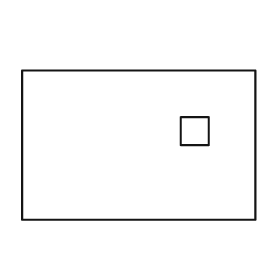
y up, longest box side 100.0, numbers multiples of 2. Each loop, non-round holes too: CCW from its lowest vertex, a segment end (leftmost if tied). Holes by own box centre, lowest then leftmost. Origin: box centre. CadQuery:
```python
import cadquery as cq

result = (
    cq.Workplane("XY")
    .moveTo(-50.0, -32.0)
    .lineTo(50.0, -32.0)
    .lineTo(50.0, 32.0)
    .lineTo(-50.0, 32.0)
    .close()
    .moveTo(18.0, 0.0)
    .lineTo(30.0, 0.0)
    .lineTo(30.0, 12.0)
    .lineTo(18.0, 12.0)
    .close()
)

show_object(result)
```